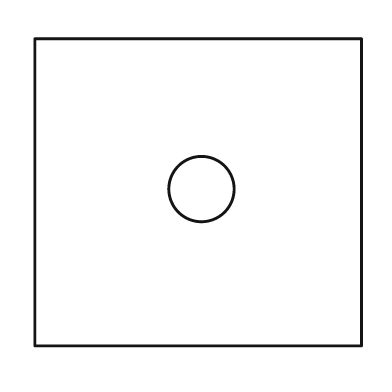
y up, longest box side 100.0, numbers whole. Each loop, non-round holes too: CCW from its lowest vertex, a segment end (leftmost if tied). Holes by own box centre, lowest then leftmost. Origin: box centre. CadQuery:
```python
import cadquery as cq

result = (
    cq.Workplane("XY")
    .moveTo(-50.0, -47.0)
    .lineTo(50.0, -47.0)
    .lineTo(50.0, 47.0)
    .lineTo(-50.0, 47.0)
    .close()
    .moveTo(1.0, 1.0)
    .circle(10.0)
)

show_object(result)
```